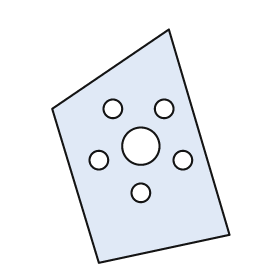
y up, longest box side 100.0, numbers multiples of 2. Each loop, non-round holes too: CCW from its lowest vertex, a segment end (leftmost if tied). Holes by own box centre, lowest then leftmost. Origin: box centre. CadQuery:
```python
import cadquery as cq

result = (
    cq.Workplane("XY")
    .moveTo(-18.0, -50.0)
    .lineTo(38.0, -38.0)
    .lineTo(12.0, 50.0)
    .lineTo(-38.0, 16.0)
    .close()
    .moveTo(0.0, -20.0)
    .circle(4.0)
    .moveTo(-18.0, -6.0)
    .circle(4.0)
    .moveTo(18.0, -6.0)
    .circle(4.0)
    .moveTo(0.0, 0.0)
    .circle(8.0)
    .moveTo(-12.0, 16.0)
    .circle(4.0)
    .moveTo(10.0, 16.0)
    .circle(4.0)
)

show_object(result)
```